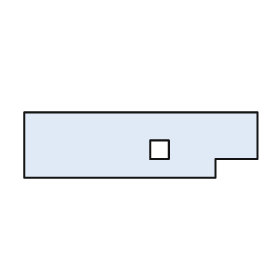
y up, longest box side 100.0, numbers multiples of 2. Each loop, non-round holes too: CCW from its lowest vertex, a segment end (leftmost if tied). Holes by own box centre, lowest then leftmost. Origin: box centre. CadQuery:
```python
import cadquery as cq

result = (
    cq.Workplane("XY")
    .moveTo(-50.0, -14.0)
    .lineTo(32.0, -14.0)
    .lineTo(32.0, -6.0)
    .lineTo(50.0, -6.0)
    .lineTo(50.0, 14.0)
    .lineTo(-50.0, 14.0)
    .close()
    .moveTo(4.0, -6.0)
    .lineTo(12.0, -6.0)
    .lineTo(12.0, 2.0)
    .lineTo(4.0, 2.0)
    .close()
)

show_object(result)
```